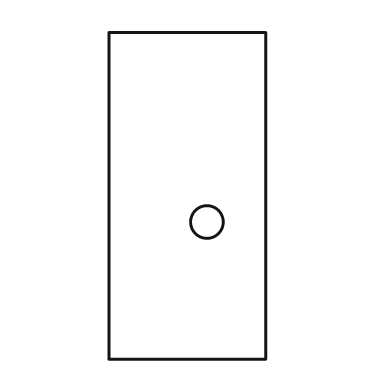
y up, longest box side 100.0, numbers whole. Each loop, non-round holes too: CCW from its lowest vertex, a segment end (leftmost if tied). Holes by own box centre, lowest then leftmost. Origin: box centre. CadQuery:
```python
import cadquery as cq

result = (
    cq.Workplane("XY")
    .moveTo(-24.0, -50.0)
    .lineTo(24.0, -50.0)
    .lineTo(24.0, 50.0)
    .lineTo(-24.0, 50.0)
    .close()
    .moveTo(6.0, -8.0)
    .circle(5.0)
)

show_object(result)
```